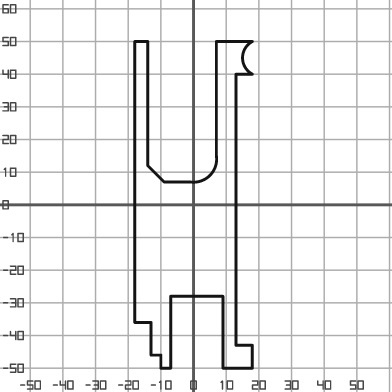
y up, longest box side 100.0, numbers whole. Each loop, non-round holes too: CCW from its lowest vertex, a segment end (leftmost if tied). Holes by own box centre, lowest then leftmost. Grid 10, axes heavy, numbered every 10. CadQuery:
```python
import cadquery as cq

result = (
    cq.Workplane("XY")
    .moveTo(-10.0, -50.0)
    .lineTo(-7.0, -50.0)
    .lineTo(-7.0, -28.0)
    .lineTo(9.0, -28.0)
    .lineTo(9.0, -50.0)
    .lineTo(18.0, -50.0)
    .lineTo(18.0, -43.0)
    .lineTo(13.0, -43.0)
    .lineTo(13.0, 40.0)
    .lineTo(18.0, 40.0)
    .threePointArc((15.0, 45.0), (18.0, 50.0))
    .lineTo(7.0, 50.0)
    .lineTo(7.0, 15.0)
    .threePointArc((5.0, 9.0), (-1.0, 7.0))
    .lineTo(-9.0, 7.0)
    .lineTo(-14.0, 12.0)
    .lineTo(-14.0, 50.0)
    .lineTo(-18.0, 50.0)
    .lineTo(-18.0, -36.0)
    .lineTo(-13.0, -36.0)
    .lineTo(-13.0, -46.0)
    .lineTo(-10.0, -46.0)
    .close()
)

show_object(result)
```